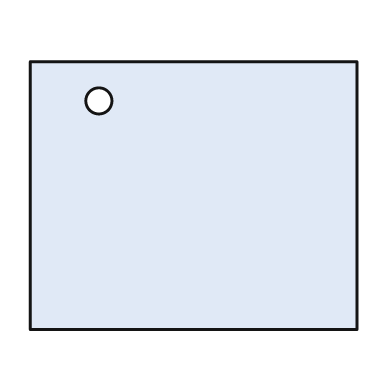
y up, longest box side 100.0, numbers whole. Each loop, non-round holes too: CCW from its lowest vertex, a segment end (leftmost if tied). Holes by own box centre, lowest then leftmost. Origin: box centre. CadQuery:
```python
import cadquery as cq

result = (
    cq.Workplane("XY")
    .moveTo(-50.0, -41.0)
    .lineTo(50.0, -41.0)
    .lineTo(50.0, 41.0)
    .lineTo(-50.0, 41.0)
    .close()
    .moveTo(-29.0, 29.0)
    .circle(4.0)
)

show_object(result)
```